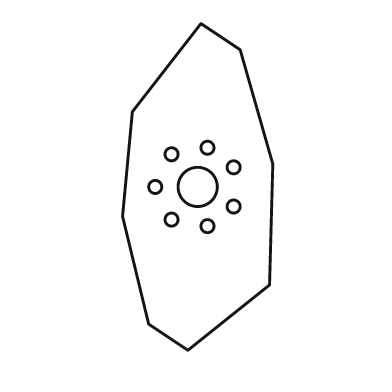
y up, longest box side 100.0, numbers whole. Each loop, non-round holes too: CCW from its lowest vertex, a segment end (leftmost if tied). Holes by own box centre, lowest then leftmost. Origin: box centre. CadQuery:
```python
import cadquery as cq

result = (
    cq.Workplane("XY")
    .moveTo(-3.0, -50.0)
    .lineTo(22.0, -30.0)
    .lineTo(23.0, 7.0)
    .lineTo(13.0, 42.0)
    .lineTo(1.0, 50.0)
    .lineTo(-20.0, 23.0)
    .lineTo(-23.0, -9.0)
    .lineTo(-15.0, -42.0)
    .close()
    .moveTo(3.0, -12.0)
    .circle(2.0)
    .moveTo(-8.0, -10.0)
    .circle(2.0)
    .moveTo(11.0, -6.0)
    .circle(2.0)
    .moveTo(-13.0, 0.0)
    .circle(2.0)
    .moveTo(0.0, 0.0)
    .circle(6.0)
    .moveTo(11.0, 6.0)
    .circle(2.0)
    .moveTo(-8.0, 10.0)
    .circle(2.0)
    .moveTo(3.0, 12.0)
    .circle(2.0)
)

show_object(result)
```